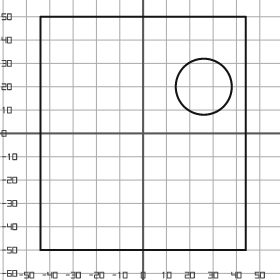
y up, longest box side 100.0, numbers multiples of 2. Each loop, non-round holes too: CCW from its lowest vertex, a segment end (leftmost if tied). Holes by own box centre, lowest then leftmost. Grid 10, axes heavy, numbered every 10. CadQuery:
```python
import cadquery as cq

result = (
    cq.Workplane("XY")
    .moveTo(-44.0, -50.0)
    .lineTo(44.0, -50.0)
    .lineTo(44.0, 50.0)
    .lineTo(-44.0, 50.0)
    .close()
    .moveTo(26.0, 20.0)
    .circle(12.0)
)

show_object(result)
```